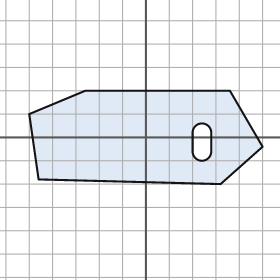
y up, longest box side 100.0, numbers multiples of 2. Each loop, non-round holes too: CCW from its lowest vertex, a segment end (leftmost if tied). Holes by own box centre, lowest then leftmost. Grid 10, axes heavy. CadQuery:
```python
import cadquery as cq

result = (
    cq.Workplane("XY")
    .moveTo(32.0, -20.0)
    .lineTo(50.0, -4.0)
    .lineTo(36.0, 20.0)
    .lineTo(-26.0, 20.0)
    .lineTo(-50.0, 10.0)
    .lineTo(-46.0, -18.0)
    .close()
    .moveTo(20.0, -6.0)
    .threePointArc((24.0, -10.0), (28.0, -6.0))
    .lineTo(28.0, 2.0)
    .threePointArc((24.0, 6.0), (20.0, 2.0))
    .close()
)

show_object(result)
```